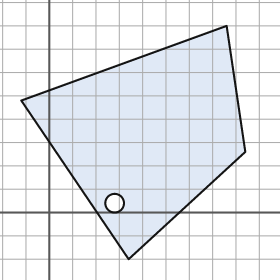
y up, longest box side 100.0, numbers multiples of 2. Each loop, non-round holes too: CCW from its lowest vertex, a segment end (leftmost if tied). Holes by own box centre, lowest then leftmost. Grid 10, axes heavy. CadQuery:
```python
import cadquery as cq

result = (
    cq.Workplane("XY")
    .moveTo(34.0, -20.0)
    .lineTo(84.0, 26.0)
    .lineTo(76.0, 80.0)
    .lineTo(-12.0, 48.0)
    .close()
    .moveTo(28.0, 4.0)
    .circle(4.0)
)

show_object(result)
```